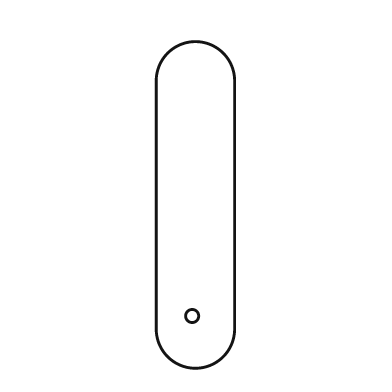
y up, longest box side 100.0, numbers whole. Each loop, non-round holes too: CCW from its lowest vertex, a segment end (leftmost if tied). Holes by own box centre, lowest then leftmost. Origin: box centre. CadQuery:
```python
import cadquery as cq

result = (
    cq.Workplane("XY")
    .moveTo(-12.0, -38.0)
    .threePointArc((0.0, -50.0), (12.0, -38.0))
    .lineTo(12.0, 38.0)
    .threePointArc((0.0, 50.0), (-12.0, 38.0))
    .close()
    .moveTo(-1.0, -34.0)
    .circle(2.0)
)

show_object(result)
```